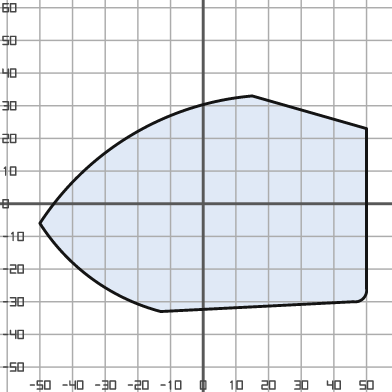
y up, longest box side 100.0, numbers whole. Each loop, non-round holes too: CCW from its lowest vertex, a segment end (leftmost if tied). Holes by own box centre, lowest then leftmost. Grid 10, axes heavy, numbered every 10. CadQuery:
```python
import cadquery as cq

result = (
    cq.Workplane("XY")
    .moveTo(-13.0, -33.0)
    .lineTo(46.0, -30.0)
    .threePointArc((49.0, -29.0), (50.0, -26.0))
    .lineTo(50.0, 23.0)
    .lineTo(15.0, 33.0)
    .threePointArc((-22.0, 21.0), (-50.0, -6.0))
    .threePointArc((-34.0, -23.0), (-13.0, -33.0))
    .close()
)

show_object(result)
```